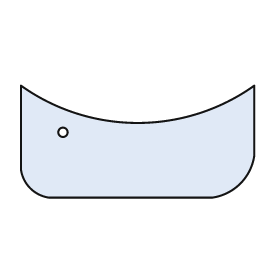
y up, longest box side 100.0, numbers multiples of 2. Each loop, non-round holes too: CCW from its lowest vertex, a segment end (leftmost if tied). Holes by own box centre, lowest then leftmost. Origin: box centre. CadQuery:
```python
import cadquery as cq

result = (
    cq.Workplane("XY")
    .moveTo(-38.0, -24.0)
    .lineTo(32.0, -24.0)
    .threePointArc((44.0, -18.0), (50.0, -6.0))
    .lineTo(50.0, 24.0)
    .threePointArc((0.0, 8.0), (-50.0, 24.0))
    .lineTo(-50.0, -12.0)
    .threePointArc((-46.0, -20.0), (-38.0, -24.0))
    .close()
    .moveTo(-32.0, 4.0)
    .circle(2.0)
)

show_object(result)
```